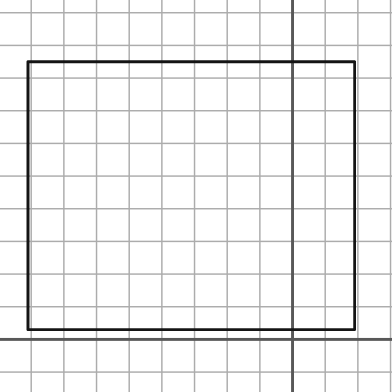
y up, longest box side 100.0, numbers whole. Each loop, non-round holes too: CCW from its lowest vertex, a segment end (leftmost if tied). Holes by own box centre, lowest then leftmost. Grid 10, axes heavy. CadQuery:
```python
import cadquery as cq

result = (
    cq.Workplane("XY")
    .moveTo(-81.0, 3.0)
    .lineTo(19.0, 3.0)
    .lineTo(19.0, 85.0)
    .lineTo(-81.0, 85.0)
    .close()
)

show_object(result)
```